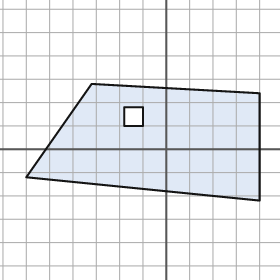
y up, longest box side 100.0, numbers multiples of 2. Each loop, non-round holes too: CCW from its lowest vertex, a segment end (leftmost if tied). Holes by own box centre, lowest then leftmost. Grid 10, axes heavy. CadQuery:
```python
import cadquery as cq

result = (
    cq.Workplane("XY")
    .moveTo(40.0, -22.0)
    .lineTo(40.0, 24.0)
    .lineTo(-32.0, 28.0)
    .lineTo(-60.0, -12.0)
    .close()
    .moveTo(-18.0, 10.0)
    .lineTo(-10.0, 10.0)
    .lineTo(-10.0, 18.0)
    .lineTo(-18.0, 18.0)
    .close()
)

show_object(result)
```